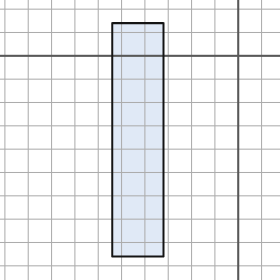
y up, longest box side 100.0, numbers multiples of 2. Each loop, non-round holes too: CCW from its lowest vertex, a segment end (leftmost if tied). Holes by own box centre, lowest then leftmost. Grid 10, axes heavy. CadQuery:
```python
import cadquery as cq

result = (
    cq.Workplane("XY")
    .moveTo(-54.0, -86.0)
    .lineTo(-32.0, -86.0)
    .lineTo(-32.0, 14.0)
    .lineTo(-54.0, 14.0)
    .close()
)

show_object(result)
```